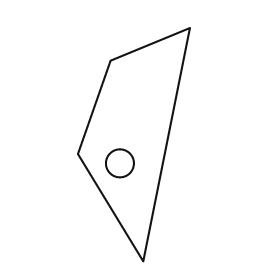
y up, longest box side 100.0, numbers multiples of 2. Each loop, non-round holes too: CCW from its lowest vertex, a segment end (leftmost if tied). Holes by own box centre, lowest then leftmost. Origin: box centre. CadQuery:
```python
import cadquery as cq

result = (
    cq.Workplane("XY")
    .moveTo(4.0, -50.0)
    .lineTo(24.0, 50.0)
    .lineTo(-10.0, 36.0)
    .lineTo(-24.0, -4.0)
    .close()
    .moveTo(-6.0, -8.0)
    .circle(6.0)
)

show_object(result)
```